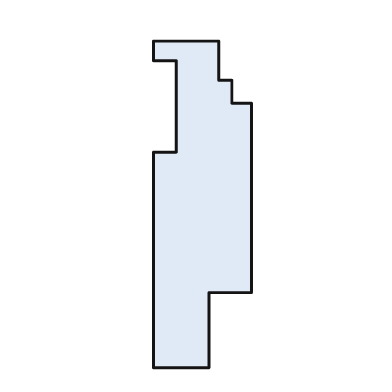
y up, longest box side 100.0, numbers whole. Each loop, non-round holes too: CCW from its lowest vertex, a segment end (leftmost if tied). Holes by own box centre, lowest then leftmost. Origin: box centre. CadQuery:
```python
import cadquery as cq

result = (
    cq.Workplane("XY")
    .moveTo(-15.0, -50.0)
    .lineTo(2.0, -50.0)
    .lineTo(2.0, -27.0)
    .lineTo(15.0, -27.0)
    .lineTo(15.0, 31.0)
    .lineTo(9.0, 31.0)
    .lineTo(9.0, 38.0)
    .lineTo(5.0, 38.0)
    .lineTo(5.0, 50.0)
    .lineTo(-15.0, 50.0)
    .lineTo(-15.0, 44.0)
    .lineTo(-8.0, 44.0)
    .lineTo(-8.0, 16.0)
    .lineTo(-15.0, 16.0)
    .close()
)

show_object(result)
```